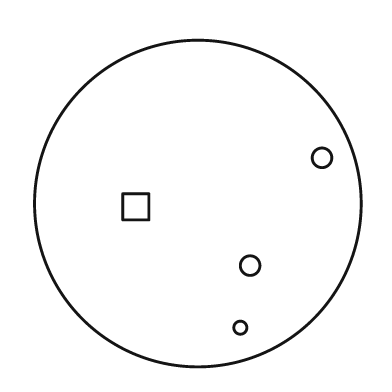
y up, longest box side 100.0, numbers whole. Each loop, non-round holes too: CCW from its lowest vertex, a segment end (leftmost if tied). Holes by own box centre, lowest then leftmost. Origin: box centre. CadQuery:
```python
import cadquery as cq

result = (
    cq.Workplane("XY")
    .moveTo(0.0, 0.0)
    .circle(50.0)
    .moveTo(13.0, -38.0)
    .circle(2.0)
    .moveTo(16.0, -19.0)
    .circle(3.0)
    .moveTo(-23.0, -5.0)
    .lineTo(-15.0, -5.0)
    .lineTo(-15.0, 3.0)
    .lineTo(-23.0, 3.0)
    .close()
    .moveTo(38.0, 14.0)
    .circle(3.0)
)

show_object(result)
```